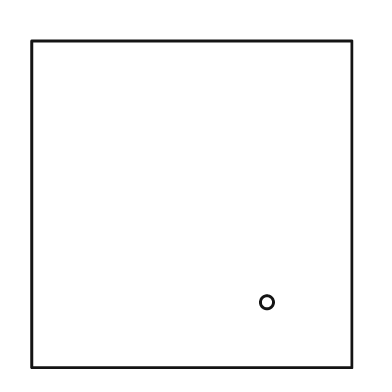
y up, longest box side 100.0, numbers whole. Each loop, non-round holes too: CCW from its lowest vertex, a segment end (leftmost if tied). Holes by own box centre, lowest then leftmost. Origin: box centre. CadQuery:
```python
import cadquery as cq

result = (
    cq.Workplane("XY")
    .moveTo(-49.0, -50.0)
    .lineTo(49.0, -50.0)
    .lineTo(49.0, 50.0)
    .lineTo(-49.0, 50.0)
    .close()
    .moveTo(23.0, -30.0)
    .circle(2.0)
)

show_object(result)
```